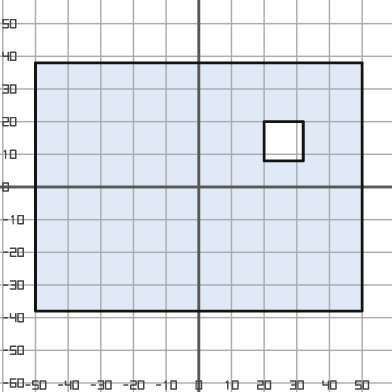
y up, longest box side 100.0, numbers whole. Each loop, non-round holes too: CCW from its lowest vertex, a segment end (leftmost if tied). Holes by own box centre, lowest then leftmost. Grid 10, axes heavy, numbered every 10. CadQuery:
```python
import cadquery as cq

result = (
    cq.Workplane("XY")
    .moveTo(-50.0, -38.0)
    .lineTo(50.0, -38.0)
    .lineTo(50.0, 38.0)
    .lineTo(-50.0, 38.0)
    .close()
    .moveTo(20.0, 8.0)
    .lineTo(32.0, 8.0)
    .lineTo(32.0, 20.0)
    .lineTo(20.0, 20.0)
    .close()
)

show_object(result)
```